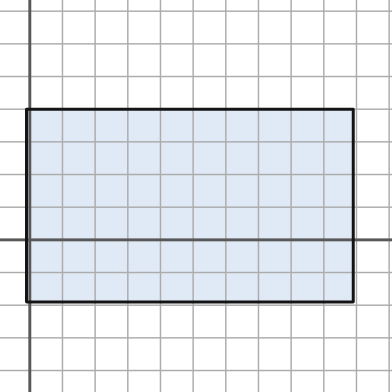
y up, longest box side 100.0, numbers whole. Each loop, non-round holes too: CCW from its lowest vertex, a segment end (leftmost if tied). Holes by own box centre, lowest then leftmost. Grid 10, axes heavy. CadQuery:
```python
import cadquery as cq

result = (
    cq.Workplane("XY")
    .moveTo(-1.0, -19.0)
    .lineTo(99.0, -19.0)
    .lineTo(99.0, 40.0)
    .lineTo(-1.0, 40.0)
    .close()
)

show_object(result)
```